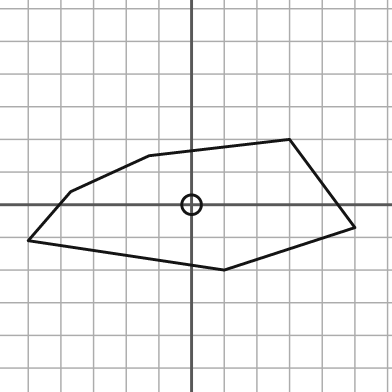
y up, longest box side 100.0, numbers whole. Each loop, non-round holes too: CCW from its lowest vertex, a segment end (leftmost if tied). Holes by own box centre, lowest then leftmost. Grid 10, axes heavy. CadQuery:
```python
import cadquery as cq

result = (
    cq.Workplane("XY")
    .moveTo(10.0, -20.0)
    .lineTo(50.0, -7.0)
    .lineTo(30.0, 20.0)
    .lineTo(-13.0, 15.0)
    .lineTo(-37.0, 4.0)
    .lineTo(-50.0, -11.0)
    .close()
    .moveTo(0.0, 0.0)
    .circle(3.0)
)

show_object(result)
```